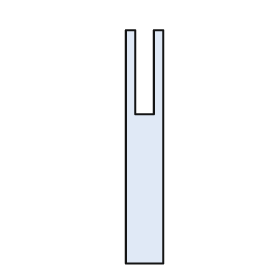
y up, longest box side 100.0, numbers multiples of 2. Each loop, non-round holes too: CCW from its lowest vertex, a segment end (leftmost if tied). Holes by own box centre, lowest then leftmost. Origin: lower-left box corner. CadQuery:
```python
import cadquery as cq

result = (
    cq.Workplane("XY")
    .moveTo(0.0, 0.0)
    .lineTo(16.0, 0.0)
    .lineTo(16.0, 100.0)
    .lineTo(12.0, 100.0)
    .lineTo(12.0, 64.0)
    .lineTo(4.0, 64.0)
    .lineTo(4.0, 100.0)
    .lineTo(0.0, 100.0)
    .close()
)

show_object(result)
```